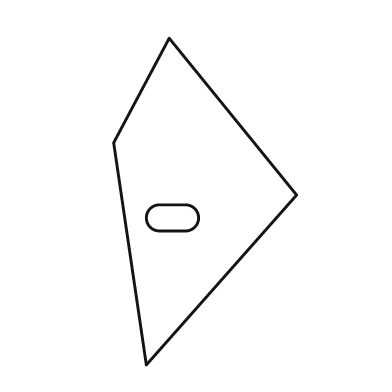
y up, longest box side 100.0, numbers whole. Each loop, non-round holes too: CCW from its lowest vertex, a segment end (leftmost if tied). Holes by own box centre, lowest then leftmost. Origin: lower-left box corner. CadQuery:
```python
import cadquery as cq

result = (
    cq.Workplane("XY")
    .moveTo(10.0, 0.0)
    .lineTo(56.0, 52.0)
    .lineTo(17.0, 100.0)
    .lineTo(0.0, 68.0)
    .close()
    .moveTo(14.0, 41.0)
    .lineTo(22.0, 41.0)
    .threePointArc((26.0, 45.0), (22.0, 49.0))
    .lineTo(14.0, 49.0)
    .threePointArc((10.0, 45.0), (14.0, 41.0))
    .close()
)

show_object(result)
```